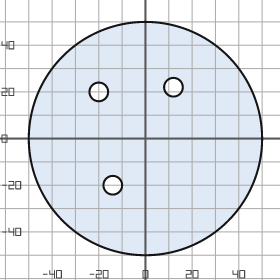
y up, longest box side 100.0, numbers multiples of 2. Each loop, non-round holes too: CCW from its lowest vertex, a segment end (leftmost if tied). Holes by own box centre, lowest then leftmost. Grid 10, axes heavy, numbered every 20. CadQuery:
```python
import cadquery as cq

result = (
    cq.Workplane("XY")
    .moveTo(0.0, 0.0)
    .circle(50.0)
    .moveTo(-14.0, -20.0)
    .circle(4.0)
    .moveTo(-20.0, 20.0)
    .circle(4.0)
    .moveTo(12.0, 22.0)
    .circle(4.0)
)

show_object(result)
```